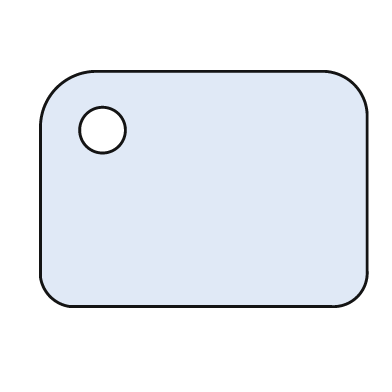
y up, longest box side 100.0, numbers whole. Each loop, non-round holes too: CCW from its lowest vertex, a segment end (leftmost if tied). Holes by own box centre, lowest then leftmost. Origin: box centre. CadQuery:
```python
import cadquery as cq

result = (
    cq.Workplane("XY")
    .moveTo(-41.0, -36.0)
    .lineTo(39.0, -36.0)
    .threePointArc((47.0, -33.0), (50.0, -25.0))
    .lineTo(50.0, 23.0)
    .threePointArc((46.0, 32.0), (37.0, 36.0))
    .lineTo(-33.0, 36.0)
    .threePointArc((-45.0, 31.0), (-50.0, 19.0))
    .lineTo(-50.0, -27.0)
    .threePointArc((-47.0, -33.0), (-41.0, -36.0))
    .close()
    .moveTo(-31.0, 18.0)
    .circle(7.0)
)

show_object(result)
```